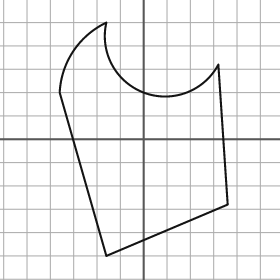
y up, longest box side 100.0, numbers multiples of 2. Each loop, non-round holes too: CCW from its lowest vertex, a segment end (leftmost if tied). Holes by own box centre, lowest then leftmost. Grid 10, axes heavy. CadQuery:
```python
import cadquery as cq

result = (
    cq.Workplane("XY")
    .moveTo(-16.0, -50.0)
    .lineTo(36.0, -28.0)
    .lineTo(32.0, 32.0)
    .threePointArc((0.0, 20.0), (-16.0, 50.0))
    .threePointArc((-30.0, 38.0), (-36.0, 20.0))
    .close()
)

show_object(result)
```